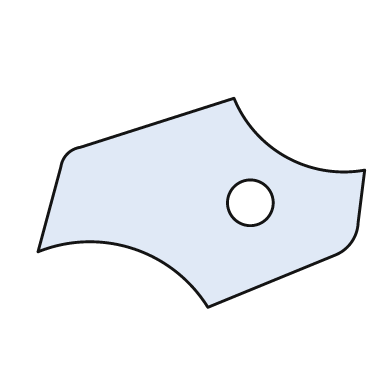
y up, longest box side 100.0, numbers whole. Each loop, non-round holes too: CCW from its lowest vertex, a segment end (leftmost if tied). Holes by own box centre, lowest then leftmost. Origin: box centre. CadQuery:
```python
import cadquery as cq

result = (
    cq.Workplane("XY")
    .moveTo(2.0, -32.0)
    .lineTo(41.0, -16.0)
    .threePointArc((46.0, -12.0), (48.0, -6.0))
    .lineTo(50.0, 10.0)
    .threePointArc((26.0, 14.0), (10.0, 32.0))
    .lineTo(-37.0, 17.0)
    .threePointArc((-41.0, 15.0), (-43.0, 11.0))
    .lineTo(-50.0, -15.0)
    .threePointArc((-21.0, -14.0), (2.0, -32.0))
    .close()
    .moveTo(15.0, 0.0)
    .circle(7.0)
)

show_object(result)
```